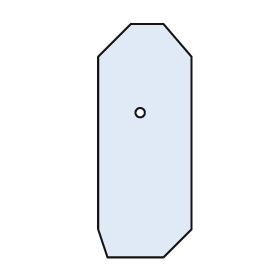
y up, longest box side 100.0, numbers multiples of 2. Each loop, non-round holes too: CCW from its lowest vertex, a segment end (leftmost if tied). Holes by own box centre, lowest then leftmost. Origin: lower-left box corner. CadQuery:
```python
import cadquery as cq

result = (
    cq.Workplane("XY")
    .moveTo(4.0, 0.0)
    .lineTo(28.0, 0.0)
    .lineTo(40.0, 12.0)
    .lineTo(40.0, 86.0)
    .lineTo(28.0, 100.0)
    .lineTo(14.0, 100.0)
    .lineTo(0.0, 86.0)
    .lineTo(0.0, 12.0)
    .close()
    .moveTo(18.0, 62.0)
    .circle(2.0)
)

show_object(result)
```